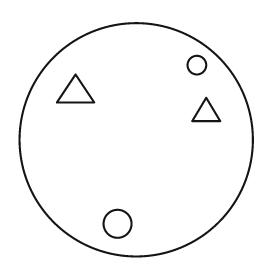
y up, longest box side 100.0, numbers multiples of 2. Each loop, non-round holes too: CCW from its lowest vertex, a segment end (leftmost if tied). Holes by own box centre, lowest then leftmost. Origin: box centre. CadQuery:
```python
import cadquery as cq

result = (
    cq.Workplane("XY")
    .moveTo(0.0, 0.0)
    .circle(50.0)
    .moveTo(-8.0, -36.0)
    .circle(6.0)
    .moveTo(24.0, 8.0)
    .lineTo(36.0, 8.0)
    .lineTo(30.0, 18.0)
    .close()
    .moveTo(-34.0, 16.0)
    .lineTo(-18.0, 16.0)
    .lineTo(-26.0, 28.0)
    .close()
    .moveTo(26.0, 32.0)
    .circle(4.0)
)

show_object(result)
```